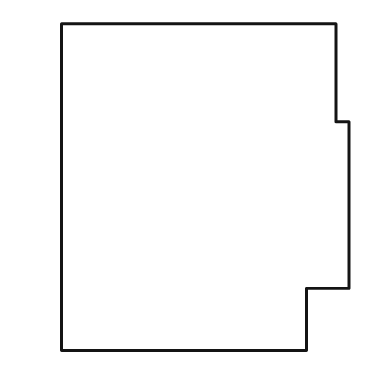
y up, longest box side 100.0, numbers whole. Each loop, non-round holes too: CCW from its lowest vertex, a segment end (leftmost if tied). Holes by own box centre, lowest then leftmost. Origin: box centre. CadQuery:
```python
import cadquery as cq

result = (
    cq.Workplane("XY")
    .moveTo(-44.0, -50.0)
    .lineTo(31.0, -50.0)
    .lineTo(31.0, -31.0)
    .lineTo(44.0, -31.0)
    .lineTo(44.0, 20.0)
    .lineTo(40.0, 20.0)
    .lineTo(40.0, 50.0)
    .lineTo(-44.0, 50.0)
    .close()
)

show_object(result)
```